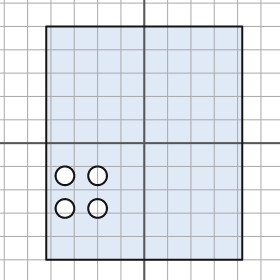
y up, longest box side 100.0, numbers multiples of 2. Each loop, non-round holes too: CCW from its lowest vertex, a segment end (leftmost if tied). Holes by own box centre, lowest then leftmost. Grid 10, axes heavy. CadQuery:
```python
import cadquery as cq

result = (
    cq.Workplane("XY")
    .moveTo(-42.0, -50.0)
    .lineTo(42.0, -50.0)
    .lineTo(42.0, 50.0)
    .lineTo(-42.0, 50.0)
    .close()
    .moveTo(-34.0, -28.0)
    .circle(4.0)
    .moveTo(-20.0, -28.0)
    .circle(4.0)
    .moveTo(-34.0, -14.0)
    .circle(4.0)
    .moveTo(-20.0, -14.0)
    .circle(4.0)
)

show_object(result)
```